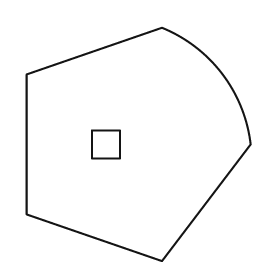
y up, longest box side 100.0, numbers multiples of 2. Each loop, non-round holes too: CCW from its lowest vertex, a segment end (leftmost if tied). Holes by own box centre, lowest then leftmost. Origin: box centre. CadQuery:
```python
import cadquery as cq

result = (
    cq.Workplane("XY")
    .moveTo(10.0, -50.0)
    .lineTo(48.0, 0.0)
    .threePointArc((36.0, 30.0), (10.0, 50.0))
    .lineTo(-48.0, 30.0)
    .lineTo(-48.0, -30.0)
    .close()
    .moveTo(-20.0, -6.0)
    .lineTo(-8.0, -6.0)
    .lineTo(-8.0, 6.0)
    .lineTo(-20.0, 6.0)
    .close()
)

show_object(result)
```